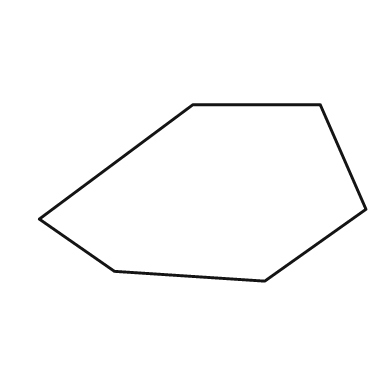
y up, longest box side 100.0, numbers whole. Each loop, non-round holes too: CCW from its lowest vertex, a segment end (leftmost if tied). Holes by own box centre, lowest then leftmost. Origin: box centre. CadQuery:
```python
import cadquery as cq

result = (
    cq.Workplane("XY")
    .moveTo(19.0, -27.0)
    .lineTo(50.0, -5.0)
    .lineTo(36.0, 27.0)
    .lineTo(-3.0, 27.0)
    .lineTo(-50.0, -8.0)
    .lineTo(-27.0, -24.0)
    .close()
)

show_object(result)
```